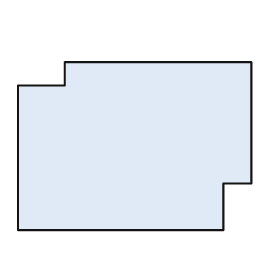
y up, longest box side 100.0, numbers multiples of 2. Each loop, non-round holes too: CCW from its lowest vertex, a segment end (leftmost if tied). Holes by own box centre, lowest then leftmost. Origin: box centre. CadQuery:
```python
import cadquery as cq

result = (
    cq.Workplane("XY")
    .moveTo(-50.0, -36.0)
    .lineTo(38.0, -36.0)
    .lineTo(38.0, -16.0)
    .lineTo(50.0, -16.0)
    .lineTo(50.0, 36.0)
    .lineTo(-30.0, 36.0)
    .lineTo(-30.0, 26.0)
    .lineTo(-50.0, 26.0)
    .close()
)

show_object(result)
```